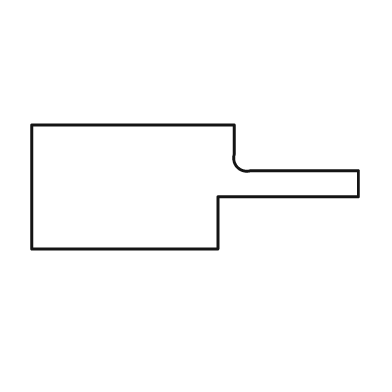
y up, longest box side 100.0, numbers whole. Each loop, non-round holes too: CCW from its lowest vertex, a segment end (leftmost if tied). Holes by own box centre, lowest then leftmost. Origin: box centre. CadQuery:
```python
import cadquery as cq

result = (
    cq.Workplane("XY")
    .moveTo(-50.0, -19.0)
    .lineTo(7.0, -19.0)
    .lineTo(7.0, -3.0)
    .lineTo(50.0, -3.0)
    .lineTo(50.0, 5.0)
    .lineTo(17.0, 5.0)
    .threePointArc((13.0, 6.0), (12.0, 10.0))
    .lineTo(12.0, 19.0)
    .lineTo(-50.0, 19.0)
    .close()
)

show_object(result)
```